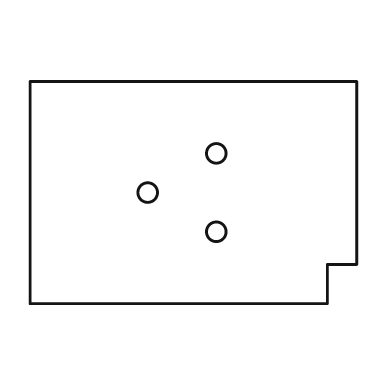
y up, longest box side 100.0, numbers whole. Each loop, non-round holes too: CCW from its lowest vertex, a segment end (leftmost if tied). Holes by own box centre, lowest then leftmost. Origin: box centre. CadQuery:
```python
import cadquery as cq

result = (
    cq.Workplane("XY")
    .moveTo(-50.0, -34.0)
    .lineTo(41.0, -34.0)
    .lineTo(41.0, -22.0)
    .lineTo(50.0, -22.0)
    .lineTo(50.0, 34.0)
    .lineTo(-50.0, 34.0)
    .close()
    .moveTo(7.0, -12.0)
    .circle(3.0)
    .moveTo(-14.0, 0.0)
    .circle(3.0)
    .moveTo(7.0, 12.0)
    .circle(3.0)
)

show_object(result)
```